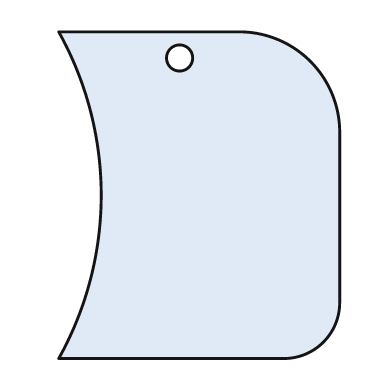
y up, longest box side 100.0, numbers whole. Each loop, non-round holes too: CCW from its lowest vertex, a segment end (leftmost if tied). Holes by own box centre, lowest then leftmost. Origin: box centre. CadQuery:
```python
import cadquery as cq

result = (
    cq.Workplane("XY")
    .moveTo(-43.0, -50.0)
    .lineTo(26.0, -50.0)
    .threePointArc((38.0, -45.0), (43.0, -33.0))
    .lineTo(43.0, 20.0)
    .threePointArc((34.0, 41.0), (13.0, 50.0))
    .lineTo(-43.0, 50.0)
    .threePointArc((-30.0, 0.0), (-43.0, -50.0))
    .close()
    .moveTo(-6.0, 42.0)
    .circle(4.0)
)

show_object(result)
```